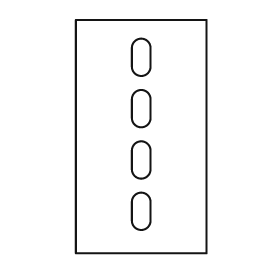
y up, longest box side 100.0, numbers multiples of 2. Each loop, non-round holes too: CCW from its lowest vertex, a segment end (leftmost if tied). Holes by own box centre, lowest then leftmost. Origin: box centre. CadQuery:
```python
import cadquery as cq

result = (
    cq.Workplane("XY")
    .moveTo(-28.0, -50.0)
    .lineTo(28.0, -50.0)
    .lineTo(28.0, 50.0)
    .lineTo(-28.0, 50.0)
    .close()
    .moveTo(-4.0, -36.0)
    .threePointArc((0.0, -40.0), (4.0, -36.0))
    .lineTo(4.0, -28.0)
    .threePointArc((0.0, -24.0), (-4.0, -28.0))
    .close()
    .moveTo(-4.0, -14.0)
    .threePointArc((0.0, -18.0), (4.0, -14.0))
    .lineTo(4.0, -6.0)
    .threePointArc((0.0, -2.0), (-4.0, -6.0))
    .close()
    .moveTo(-4.0, 8.0)
    .threePointArc((0.0, 4.0), (4.0, 8.0))
    .lineTo(4.0, 16.0)
    .threePointArc((0.0, 20.0), (-4.0, 16.0))
    .close()
    .moveTo(-4.0, 30.0)
    .threePointArc((0.0, 26.0), (4.0, 30.0))
    .lineTo(4.0, 38.0)
    .threePointArc((0.0, 42.0), (-4.0, 38.0))
    .close()
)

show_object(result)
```